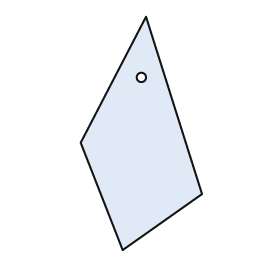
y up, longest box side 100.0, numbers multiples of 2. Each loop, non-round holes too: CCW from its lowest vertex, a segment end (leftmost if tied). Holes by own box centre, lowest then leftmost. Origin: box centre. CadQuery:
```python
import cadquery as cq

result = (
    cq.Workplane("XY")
    .moveTo(-8.0, -50.0)
    .lineTo(26.0, -26.0)
    .lineTo(2.0, 50.0)
    .lineTo(-26.0, -4.0)
    .close()
    .moveTo(0.0, 24.0)
    .circle(2.0)
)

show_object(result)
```